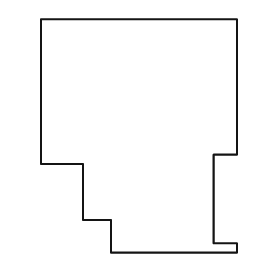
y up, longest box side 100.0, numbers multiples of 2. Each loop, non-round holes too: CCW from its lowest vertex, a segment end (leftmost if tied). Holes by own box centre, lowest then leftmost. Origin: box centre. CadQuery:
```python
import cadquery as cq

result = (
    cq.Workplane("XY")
    .moveTo(-12.0, -50.0)
    .lineTo(42.0, -50.0)
    .lineTo(42.0, -46.0)
    .lineTo(32.0, -46.0)
    .lineTo(32.0, -8.0)
    .lineTo(42.0, -8.0)
    .lineTo(42.0, 50.0)
    .lineTo(-42.0, 50.0)
    .lineTo(-42.0, -12.0)
    .lineTo(-24.0, -12.0)
    .lineTo(-24.0, -36.0)
    .lineTo(-12.0, -36.0)
    .close()
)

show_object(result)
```